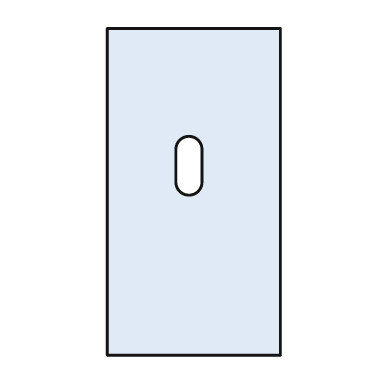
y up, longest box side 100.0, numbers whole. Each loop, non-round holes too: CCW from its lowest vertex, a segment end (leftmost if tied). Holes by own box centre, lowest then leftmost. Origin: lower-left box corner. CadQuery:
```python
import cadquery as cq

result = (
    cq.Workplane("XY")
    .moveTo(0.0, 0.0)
    .lineTo(53.0, 0.0)
    .lineTo(53.0, 100.0)
    .lineTo(0.0, 100.0)
    .close()
    .moveTo(21.0, 53.0)
    .threePointArc((25.0, 49.0), (29.0, 53.0))
    .lineTo(29.0, 63.0)
    .threePointArc((25.0, 67.0), (21.0, 63.0))
    .close()
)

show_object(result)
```